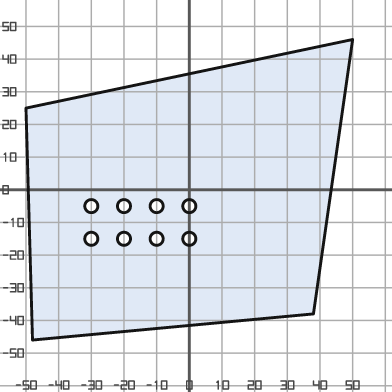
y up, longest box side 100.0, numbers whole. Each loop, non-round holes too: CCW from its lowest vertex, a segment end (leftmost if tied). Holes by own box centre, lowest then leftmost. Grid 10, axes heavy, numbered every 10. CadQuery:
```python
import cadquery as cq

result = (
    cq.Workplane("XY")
    .moveTo(-48.0, -46.0)
    .lineTo(38.0, -38.0)
    .lineTo(50.0, 46.0)
    .lineTo(-50.0, 25.0)
    .close()
    .moveTo(-30.0, -15.0)
    .circle(2.0)
    .moveTo(-20.0, -15.0)
    .circle(2.0)
    .moveTo(-10.0, -15.0)
    .circle(2.0)
    .moveTo(0.0, -15.0)
    .circle(2.0)
    .moveTo(-30.0, -5.0)
    .circle(2.0)
    .moveTo(-20.0, -5.0)
    .circle(2.0)
    .moveTo(-10.0, -5.0)
    .circle(2.0)
    .moveTo(0.0, -5.0)
    .circle(2.0)
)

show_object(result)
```